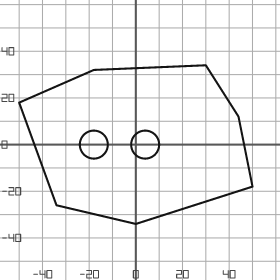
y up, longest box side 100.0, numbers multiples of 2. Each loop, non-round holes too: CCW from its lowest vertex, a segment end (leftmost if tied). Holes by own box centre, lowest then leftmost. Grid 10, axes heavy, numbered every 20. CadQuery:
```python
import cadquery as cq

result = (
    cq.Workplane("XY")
    .moveTo(0.0, -34.0)
    .lineTo(50.0, -18.0)
    .lineTo(44.0, 12.0)
    .lineTo(30.0, 34.0)
    .lineTo(-18.0, 32.0)
    .lineTo(-50.0, 18.0)
    .lineTo(-34.0, -26.0)
    .close()
    .moveTo(-18.0, 0.0)
    .circle(6.0)
    .moveTo(4.0, 0.0)
    .circle(6.0)
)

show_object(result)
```